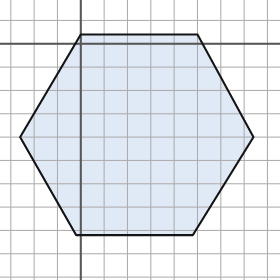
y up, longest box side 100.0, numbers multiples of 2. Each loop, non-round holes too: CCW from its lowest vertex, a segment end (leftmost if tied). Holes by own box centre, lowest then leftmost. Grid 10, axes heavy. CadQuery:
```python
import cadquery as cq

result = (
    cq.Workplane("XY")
    .moveTo(-2.0, -82.0)
    .lineTo(48.0, -82.0)
    .lineTo(74.0, -40.0)
    .lineTo(50.0, 4.0)
    .lineTo(0.0, 4.0)
    .lineTo(-26.0, -40.0)
    .close()
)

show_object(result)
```